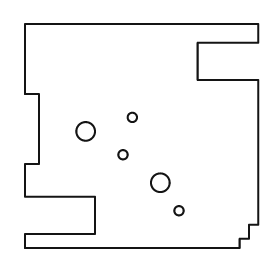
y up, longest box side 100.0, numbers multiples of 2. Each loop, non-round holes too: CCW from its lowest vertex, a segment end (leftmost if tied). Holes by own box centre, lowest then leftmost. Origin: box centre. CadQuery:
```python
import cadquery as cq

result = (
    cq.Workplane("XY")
    .moveTo(-50.0, -48.0)
    .lineTo(42.0, -48.0)
    .lineTo(42.0, -44.0)
    .lineTo(46.0, -44.0)
    .lineTo(46.0, -38.0)
    .lineTo(50.0, -38.0)
    .lineTo(50.0, 24.0)
    .lineTo(24.0, 24.0)
    .lineTo(24.0, 40.0)
    .lineTo(50.0, 40.0)
    .lineTo(50.0, 48.0)
    .lineTo(-50.0, 48.0)
    .lineTo(-50.0, 18.0)
    .lineTo(-44.0, 18.0)
    .lineTo(-44.0, -12.0)
    .lineTo(-50.0, -12.0)
    .lineTo(-50.0, -26.0)
    .lineTo(-20.0, -26.0)
    .lineTo(-20.0, -42.0)
    .lineTo(-50.0, -42.0)
    .close()
    .moveTo(16.0, -32.0)
    .circle(2.0)
    .moveTo(8.0, -20.0)
    .circle(4.0)
    .moveTo(-8.0, -8.0)
    .circle(2.0)
    .moveTo(-24.0, 2.0)
    .circle(4.0)
    .moveTo(-4.0, 8.0)
    .circle(2.0)
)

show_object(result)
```